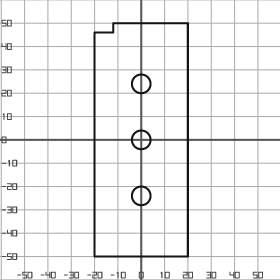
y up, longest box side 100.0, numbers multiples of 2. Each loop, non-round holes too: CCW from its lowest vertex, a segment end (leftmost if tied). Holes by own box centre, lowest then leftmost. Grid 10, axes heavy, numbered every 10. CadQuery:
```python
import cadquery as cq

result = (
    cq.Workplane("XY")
    .moveTo(-20.0, -50.0)
    .lineTo(20.0, -50.0)
    .lineTo(20.0, 50.0)
    .lineTo(-12.0, 50.0)
    .lineTo(-12.0, 46.0)
    .lineTo(-20.0, 46.0)
    .close()
    .moveTo(0.0, -24.0)
    .circle(4.0)
    .moveTo(0.0, 0.0)
    .circle(4.0)
    .moveTo(0.0, 24.0)
    .circle(4.0)
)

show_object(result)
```